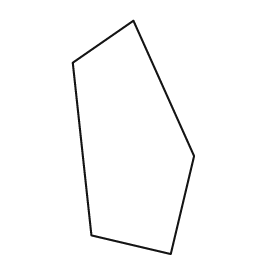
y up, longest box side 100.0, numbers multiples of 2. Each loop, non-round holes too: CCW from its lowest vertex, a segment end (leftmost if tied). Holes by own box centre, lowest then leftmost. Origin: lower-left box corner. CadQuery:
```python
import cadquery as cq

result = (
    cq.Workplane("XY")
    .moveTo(42.0, 0.0)
    .lineTo(52.0, 42.0)
    .lineTo(26.0, 100.0)
    .lineTo(0.0, 82.0)
    .lineTo(8.0, 8.0)
    .close()
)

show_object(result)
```